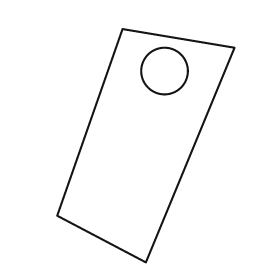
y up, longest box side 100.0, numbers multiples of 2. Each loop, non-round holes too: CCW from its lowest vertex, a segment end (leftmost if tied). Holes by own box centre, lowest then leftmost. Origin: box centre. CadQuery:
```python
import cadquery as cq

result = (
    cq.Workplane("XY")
    .moveTo(0.0, -50.0)
    .lineTo(38.0, 42.0)
    .lineTo(-10.0, 50.0)
    .lineTo(-38.0, -30.0)
    .close()
    .moveTo(8.0, 32.0)
    .circle(10.0)
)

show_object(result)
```